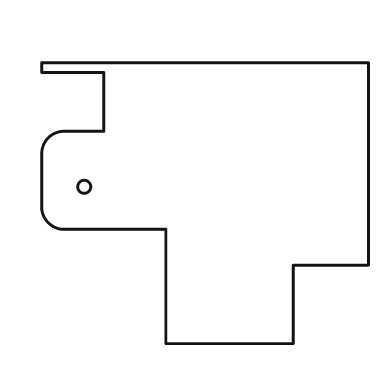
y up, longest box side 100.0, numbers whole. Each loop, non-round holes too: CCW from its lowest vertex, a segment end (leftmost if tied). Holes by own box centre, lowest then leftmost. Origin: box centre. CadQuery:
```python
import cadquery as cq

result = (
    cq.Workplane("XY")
    .moveTo(-12.0, -43.0)
    .lineTo(27.0, -43.0)
    .lineTo(27.0, -19.0)
    .lineTo(50.0, -19.0)
    .lineTo(50.0, 43.0)
    .lineTo(-50.0, 43.0)
    .lineTo(-50.0, 40.0)
    .lineTo(-31.0, 40.0)
    .lineTo(-31.0, 22.0)
    .lineTo(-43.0, 22.0)
    .threePointArc((-48.0, 20.0), (-50.0, 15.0))
    .lineTo(-50.0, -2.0)
    .threePointArc((-48.0, -6.0), (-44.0, -8.0))
    .lineTo(-12.0, -8.0)
    .close()
    .moveTo(-37.0, 5.0)
    .circle(2.0)
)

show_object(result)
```